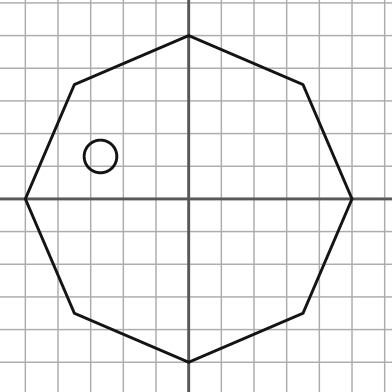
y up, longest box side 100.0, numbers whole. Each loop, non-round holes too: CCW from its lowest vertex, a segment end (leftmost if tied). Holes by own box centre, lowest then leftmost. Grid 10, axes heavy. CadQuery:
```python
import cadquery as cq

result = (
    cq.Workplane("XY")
    .moveTo(0.0, -50.0)
    .lineTo(35.0, -35.0)
    .lineTo(50.0, 0.0)
    .lineTo(35.0, 35.0)
    .lineTo(0.0, 50.0)
    .lineTo(-35.0, 35.0)
    .lineTo(-50.0, 0.0)
    .lineTo(-35.0, -35.0)
    .close()
    .moveTo(-27.0, 13.0)
    .circle(5.0)
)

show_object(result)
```